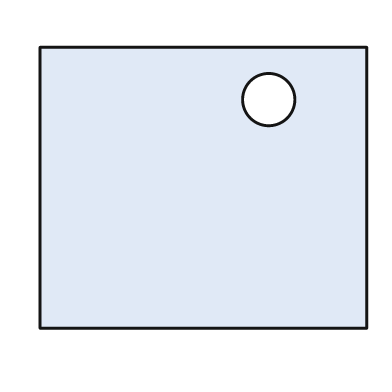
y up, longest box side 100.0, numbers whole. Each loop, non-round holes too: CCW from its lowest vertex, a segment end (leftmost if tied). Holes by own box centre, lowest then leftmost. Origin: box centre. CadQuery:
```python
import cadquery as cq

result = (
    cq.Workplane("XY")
    .moveTo(-50.0, -43.0)
    .lineTo(50.0, -43.0)
    .lineTo(50.0, 43.0)
    .lineTo(-50.0, 43.0)
    .close()
    .moveTo(20.0, 27.0)
    .circle(8.0)
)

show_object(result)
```